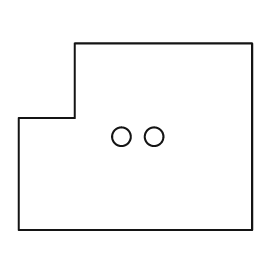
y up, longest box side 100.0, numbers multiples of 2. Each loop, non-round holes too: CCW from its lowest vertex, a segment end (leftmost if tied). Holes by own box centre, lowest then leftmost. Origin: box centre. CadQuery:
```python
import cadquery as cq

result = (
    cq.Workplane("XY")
    .moveTo(-50.0, -40.0)
    .lineTo(50.0, -40.0)
    .lineTo(50.0, 40.0)
    .lineTo(-26.0, 40.0)
    .lineTo(-26.0, 8.0)
    .lineTo(-50.0, 8.0)
    .close()
    .moveTo(-6.0, 0.0)
    .circle(4.0)
    .moveTo(8.0, 0.0)
    .circle(4.0)
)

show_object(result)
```